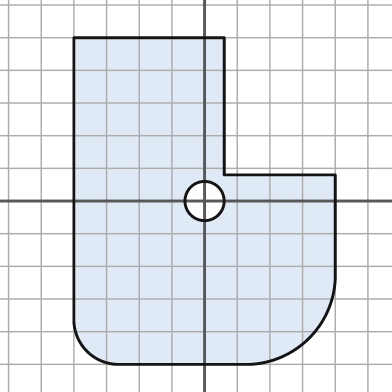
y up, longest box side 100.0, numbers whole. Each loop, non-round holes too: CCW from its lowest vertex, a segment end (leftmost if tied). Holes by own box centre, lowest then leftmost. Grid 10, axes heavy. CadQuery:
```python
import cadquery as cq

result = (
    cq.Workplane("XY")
    .moveTo(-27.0, -50.0)
    .lineTo(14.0, -50.0)
    .threePointArc((32.0, -42.0), (40.0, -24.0))
    .lineTo(40.0, 8.0)
    .lineTo(6.0, 8.0)
    .lineTo(6.0, 50.0)
    .lineTo(-40.0, 50.0)
    .lineTo(-40.0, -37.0)
    .threePointArc((-36.0, -46.0), (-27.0, -50.0))
    .close()
    .moveTo(0.0, 0.0)
    .circle(6.0)
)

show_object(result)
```